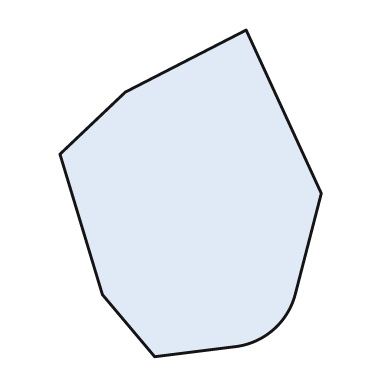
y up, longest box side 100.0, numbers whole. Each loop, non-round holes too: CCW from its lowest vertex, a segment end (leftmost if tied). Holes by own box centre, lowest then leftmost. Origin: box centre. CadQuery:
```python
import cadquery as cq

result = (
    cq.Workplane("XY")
    .moveTo(-11.0, -50.0)
    .lineTo(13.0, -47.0)
    .threePointArc((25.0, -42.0), (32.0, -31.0))
    .lineTo(40.0, 0.0)
    .lineTo(17.0, 50.0)
    .lineTo(-20.0, 31.0)
    .lineTo(-40.0, 12.0)
    .lineTo(-27.0, -31.0)
    .close()
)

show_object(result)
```